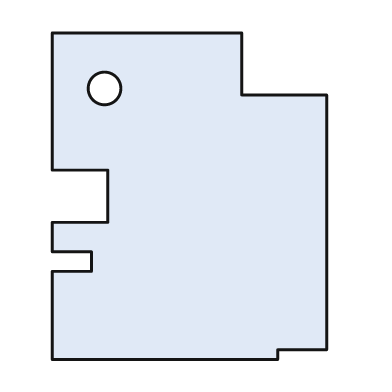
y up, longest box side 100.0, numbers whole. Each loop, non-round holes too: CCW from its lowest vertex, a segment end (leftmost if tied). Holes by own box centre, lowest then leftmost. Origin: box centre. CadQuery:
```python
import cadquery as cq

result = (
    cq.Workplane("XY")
    .moveTo(-42.0, -50.0)
    .lineTo(27.0, -50.0)
    .lineTo(27.0, -47.0)
    .lineTo(42.0, -47.0)
    .lineTo(42.0, 31.0)
    .lineTo(16.0, 31.0)
    .lineTo(16.0, 50.0)
    .lineTo(-42.0, 50.0)
    .lineTo(-42.0, 8.0)
    .lineTo(-25.0, 8.0)
    .lineTo(-25.0, -8.0)
    .lineTo(-42.0, -8.0)
    .lineTo(-42.0, -17.0)
    .lineTo(-30.0, -17.0)
    .lineTo(-30.0, -23.0)
    .lineTo(-42.0, -23.0)
    .close()
    .moveTo(-26.0, 33.0)
    .circle(5.0)
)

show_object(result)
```